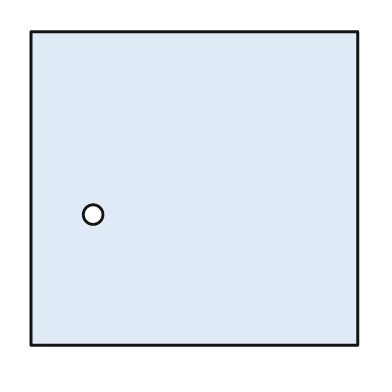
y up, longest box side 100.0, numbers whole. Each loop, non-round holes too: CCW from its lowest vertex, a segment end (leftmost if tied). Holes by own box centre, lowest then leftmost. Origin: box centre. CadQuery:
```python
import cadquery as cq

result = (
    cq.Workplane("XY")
    .moveTo(-50.0, -48.0)
    .lineTo(50.0, -48.0)
    .lineTo(50.0, 48.0)
    .lineTo(-50.0, 48.0)
    .close()
    .moveTo(-31.0, -8.0)
    .circle(3.0)
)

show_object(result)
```